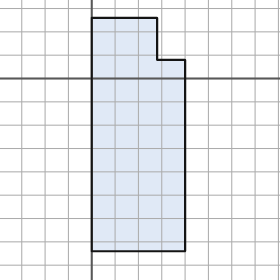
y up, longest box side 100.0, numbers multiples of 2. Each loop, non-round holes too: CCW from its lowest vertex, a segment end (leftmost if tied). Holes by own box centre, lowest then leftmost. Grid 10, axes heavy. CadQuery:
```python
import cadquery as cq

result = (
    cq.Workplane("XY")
    .moveTo(0.0, -74.0)
    .lineTo(40.0, -74.0)
    .lineTo(40.0, 8.0)
    .lineTo(28.0, 8.0)
    .lineTo(28.0, 26.0)
    .lineTo(0.0, 26.0)
    .close()
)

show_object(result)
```